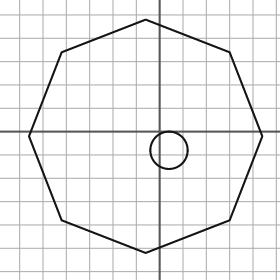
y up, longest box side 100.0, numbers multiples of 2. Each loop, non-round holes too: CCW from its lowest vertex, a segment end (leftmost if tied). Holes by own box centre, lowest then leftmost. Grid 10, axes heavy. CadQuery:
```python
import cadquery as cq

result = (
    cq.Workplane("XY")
    .moveTo(-6.0, -52.0)
    .lineTo(30.0, -38.0)
    .lineTo(44.0, -2.0)
    .lineTo(30.0, 34.0)
    .lineTo(-6.0, 48.0)
    .lineTo(-42.0, 34.0)
    .lineTo(-56.0, -2.0)
    .lineTo(-42.0, -38.0)
    .close()
    .moveTo(4.0, -8.0)
    .circle(8.0)
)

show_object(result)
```